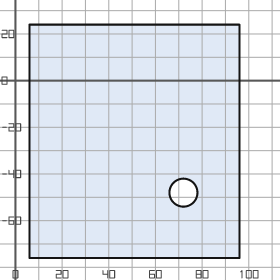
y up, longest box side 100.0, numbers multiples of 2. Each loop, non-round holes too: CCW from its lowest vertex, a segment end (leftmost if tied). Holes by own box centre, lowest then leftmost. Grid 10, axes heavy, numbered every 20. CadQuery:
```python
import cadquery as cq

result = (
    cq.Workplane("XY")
    .moveTo(6.0, -76.0)
    .lineTo(96.0, -76.0)
    .lineTo(96.0, 24.0)
    .lineTo(6.0, 24.0)
    .close()
    .moveTo(72.0, -48.0)
    .circle(6.0)
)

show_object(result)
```